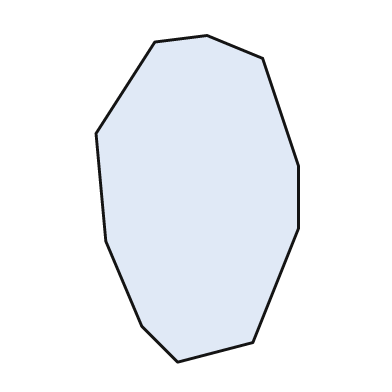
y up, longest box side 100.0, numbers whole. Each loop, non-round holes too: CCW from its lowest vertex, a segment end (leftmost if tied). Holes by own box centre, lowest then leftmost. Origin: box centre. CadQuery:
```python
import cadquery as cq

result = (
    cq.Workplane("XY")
    .moveTo(-6.0, -50.0)
    .lineTo(17.0, -44.0)
    .lineTo(31.0, -9.0)
    .lineTo(31.0, 10.0)
    .lineTo(20.0, 43.0)
    .lineTo(3.0, 50.0)
    .lineTo(-13.0, 48.0)
    .lineTo(-31.0, 20.0)
    .lineTo(-28.0, -13.0)
    .lineTo(-17.0, -39.0)
    .close()
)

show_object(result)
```